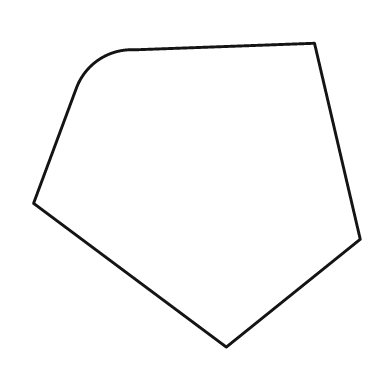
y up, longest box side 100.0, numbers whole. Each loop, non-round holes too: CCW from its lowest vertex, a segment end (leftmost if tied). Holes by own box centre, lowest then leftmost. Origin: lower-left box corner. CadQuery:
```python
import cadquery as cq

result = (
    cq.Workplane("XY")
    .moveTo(59.0, 0.0)
    .lineTo(100.0, 33.0)
    .lineTo(86.0, 93.0)
    .lineTo(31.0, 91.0)
    .threePointArc((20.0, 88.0), (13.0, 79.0))
    .lineTo(0.0, 44.0)
    .close()
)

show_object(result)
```